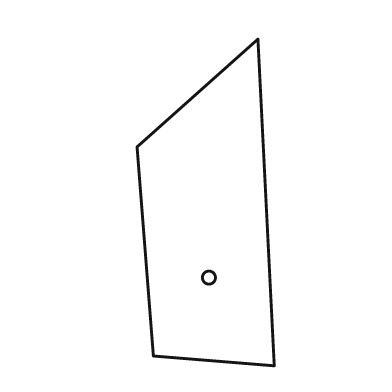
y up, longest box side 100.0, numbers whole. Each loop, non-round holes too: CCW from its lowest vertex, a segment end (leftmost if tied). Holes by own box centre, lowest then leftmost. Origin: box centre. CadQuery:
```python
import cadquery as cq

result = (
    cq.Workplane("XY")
    .moveTo(21.0, -50.0)
    .lineTo(16.0, 50.0)
    .lineTo(-21.0, 17.0)
    .lineTo(-16.0, -47.0)
    .close()
    .moveTo(1.0, -23.0)
    .circle(2.0)
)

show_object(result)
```